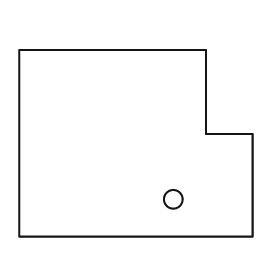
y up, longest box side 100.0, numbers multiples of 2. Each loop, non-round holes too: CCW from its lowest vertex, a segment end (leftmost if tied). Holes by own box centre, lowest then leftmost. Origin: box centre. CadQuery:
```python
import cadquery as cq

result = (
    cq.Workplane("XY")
    .moveTo(-50.0, -40.0)
    .lineTo(50.0, -40.0)
    .lineTo(50.0, 4.0)
    .lineTo(30.0, 4.0)
    .lineTo(30.0, 40.0)
    .lineTo(-50.0, 40.0)
    .close()
    .moveTo(16.0, -24.0)
    .circle(4.0)
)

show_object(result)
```